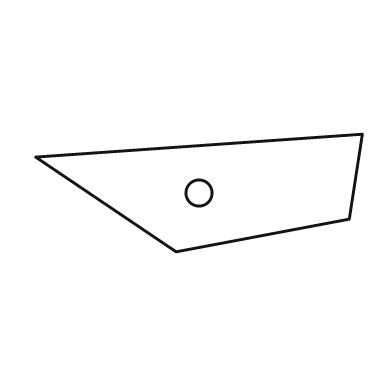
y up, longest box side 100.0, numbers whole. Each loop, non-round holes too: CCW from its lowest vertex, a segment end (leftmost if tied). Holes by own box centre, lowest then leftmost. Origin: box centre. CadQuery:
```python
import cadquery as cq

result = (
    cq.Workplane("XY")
    .moveTo(-7.0, -18.0)
    .lineTo(46.0, -8.0)
    .lineTo(50.0, 18.0)
    .lineTo(-50.0, 11.0)
    .close()
    .moveTo(0.0, 0.0)
    .circle(4.0)
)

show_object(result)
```